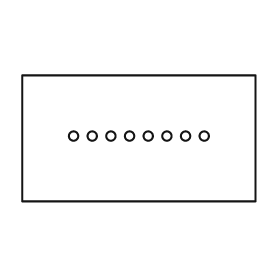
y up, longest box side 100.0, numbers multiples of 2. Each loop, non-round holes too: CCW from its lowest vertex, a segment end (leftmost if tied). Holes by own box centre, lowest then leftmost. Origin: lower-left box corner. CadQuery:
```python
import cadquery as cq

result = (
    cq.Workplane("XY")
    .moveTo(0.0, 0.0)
    .lineTo(100.0, 0.0)
    .lineTo(100.0, 54.0)
    .lineTo(0.0, 54.0)
    .close()
    .moveTo(22.0, 28.0)
    .circle(2.0)
    .moveTo(30.0, 28.0)
    .circle(2.0)
    .moveTo(38.0, 28.0)
    .circle(2.0)
    .moveTo(46.0, 28.0)
    .circle(2.0)
    .moveTo(54.0, 28.0)
    .circle(2.0)
    .moveTo(62.0, 28.0)
    .circle(2.0)
    .moveTo(70.0, 28.0)
    .circle(2.0)
    .moveTo(78.0, 28.0)
    .circle(2.0)
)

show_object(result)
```